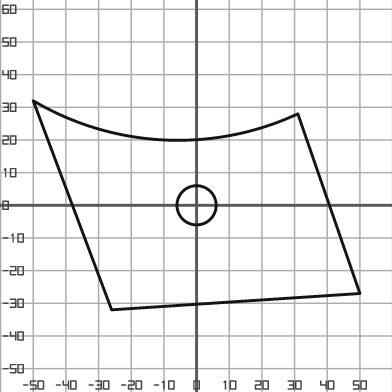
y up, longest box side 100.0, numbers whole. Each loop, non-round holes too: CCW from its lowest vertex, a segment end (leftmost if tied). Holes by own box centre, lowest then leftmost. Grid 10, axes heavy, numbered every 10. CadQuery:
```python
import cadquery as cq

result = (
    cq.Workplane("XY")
    .moveTo(-26.0, -32.0)
    .lineTo(50.0, -27.0)
    .lineTo(31.0, 28.0)
    .threePointArc((-10.0, 20.0), (-50.0, 32.0))
    .close()
    .moveTo(0.0, 0.0)
    .circle(6.0)
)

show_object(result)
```